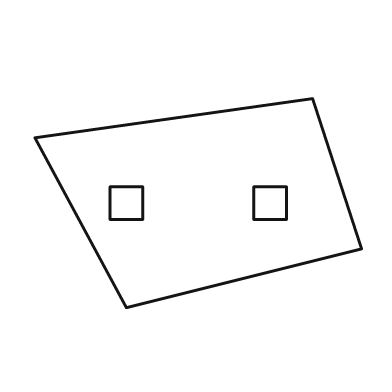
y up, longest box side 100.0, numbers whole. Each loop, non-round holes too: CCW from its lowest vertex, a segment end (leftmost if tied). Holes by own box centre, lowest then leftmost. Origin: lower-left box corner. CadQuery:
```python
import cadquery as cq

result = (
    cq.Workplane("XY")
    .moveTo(28.0, 0.0)
    .lineTo(100.0, 18.0)
    .lineTo(85.0, 64.0)
    .lineTo(0.0, 52.0)
    .close()
    .moveTo(23.0, 27.0)
    .lineTo(33.0, 27.0)
    .lineTo(33.0, 37.0)
    .lineTo(23.0, 37.0)
    .close()
    .moveTo(67.0, 27.0)
    .lineTo(77.0, 27.0)
    .lineTo(77.0, 37.0)
    .lineTo(67.0, 37.0)
    .close()
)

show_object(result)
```